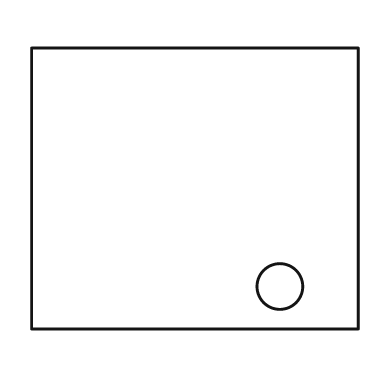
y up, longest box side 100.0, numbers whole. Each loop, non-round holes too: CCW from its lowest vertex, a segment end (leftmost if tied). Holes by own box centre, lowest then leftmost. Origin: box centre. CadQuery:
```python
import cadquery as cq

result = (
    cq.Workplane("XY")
    .moveTo(-50.0, -43.0)
    .lineTo(50.0, -43.0)
    .lineTo(50.0, 43.0)
    .lineTo(-50.0, 43.0)
    .close()
    .moveTo(26.0, -30.0)
    .circle(7.0)
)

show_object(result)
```